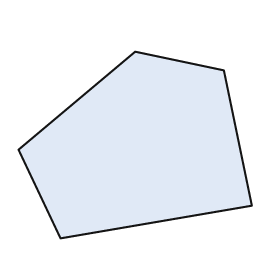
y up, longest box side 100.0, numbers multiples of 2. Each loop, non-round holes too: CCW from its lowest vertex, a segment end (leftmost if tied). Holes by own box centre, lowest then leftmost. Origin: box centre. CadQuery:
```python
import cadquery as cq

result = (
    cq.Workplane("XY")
    .moveTo(-32.0, -40.0)
    .lineTo(50.0, -26.0)
    .lineTo(38.0, 32.0)
    .lineTo(0.0, 40.0)
    .lineTo(-50.0, -2.0)
    .close()
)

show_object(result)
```